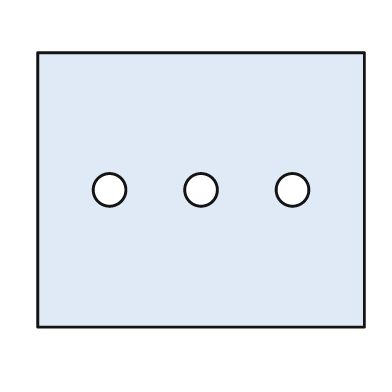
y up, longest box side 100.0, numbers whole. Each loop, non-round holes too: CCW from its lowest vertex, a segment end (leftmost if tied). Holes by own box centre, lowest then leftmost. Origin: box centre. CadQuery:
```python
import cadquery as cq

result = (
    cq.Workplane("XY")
    .moveTo(-50.0, -42.0)
    .lineTo(50.0, -42.0)
    .lineTo(50.0, 42.0)
    .lineTo(-50.0, 42.0)
    .close()
    .moveTo(-28.0, 0.0)
    .circle(5.0)
    .moveTo(0.0, 0.0)
    .circle(5.0)
    .moveTo(28.0, 0.0)
    .circle(5.0)
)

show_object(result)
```